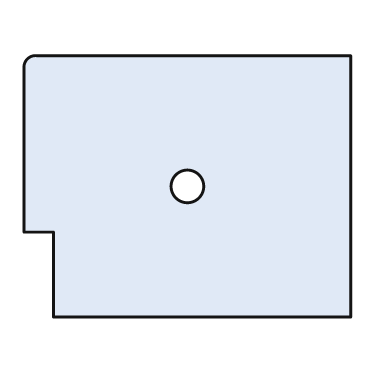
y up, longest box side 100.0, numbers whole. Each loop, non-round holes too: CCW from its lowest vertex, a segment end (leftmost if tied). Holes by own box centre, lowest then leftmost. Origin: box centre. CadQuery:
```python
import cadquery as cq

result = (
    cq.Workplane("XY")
    .moveTo(-41.0, -40.0)
    .lineTo(50.0, -40.0)
    .lineTo(50.0, 40.0)
    .lineTo(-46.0, 40.0)
    .threePointArc((-49.0, 39.0), (-50.0, 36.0))
    .lineTo(-50.0, -14.0)
    .lineTo(-41.0, -14.0)
    .close()
    .moveTo(0.0, 0.0)
    .circle(5.0)
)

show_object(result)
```